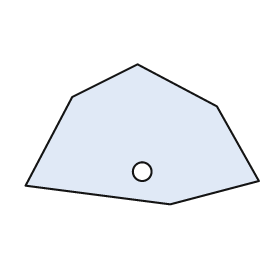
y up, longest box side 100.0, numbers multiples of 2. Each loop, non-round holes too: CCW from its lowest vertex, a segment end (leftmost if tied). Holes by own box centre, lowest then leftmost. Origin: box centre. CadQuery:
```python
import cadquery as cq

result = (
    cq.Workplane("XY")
    .moveTo(12.0, -30.0)
    .lineTo(50.0, -20.0)
    .lineTo(32.0, 12.0)
    .lineTo(-2.0, 30.0)
    .lineTo(-30.0, 16.0)
    .lineTo(-50.0, -22.0)
    .close()
    .moveTo(0.0, -16.0)
    .circle(4.0)
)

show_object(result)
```